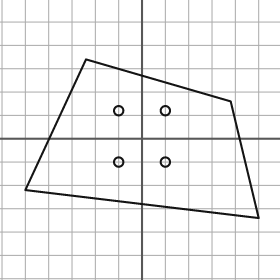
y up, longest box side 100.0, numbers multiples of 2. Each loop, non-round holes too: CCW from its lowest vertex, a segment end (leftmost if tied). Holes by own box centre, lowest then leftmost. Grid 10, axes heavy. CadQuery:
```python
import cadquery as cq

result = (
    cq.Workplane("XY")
    .moveTo(50.0, -34.0)
    .lineTo(38.0, 16.0)
    .lineTo(-24.0, 34.0)
    .lineTo(-50.0, -22.0)
    .close()
    .moveTo(-10.0, -10.0)
    .circle(2.0)
    .moveTo(10.0, -10.0)
    .circle(2.0)
    .moveTo(-10.0, 12.0)
    .circle(2.0)
    .moveTo(10.0, 12.0)
    .circle(2.0)
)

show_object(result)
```